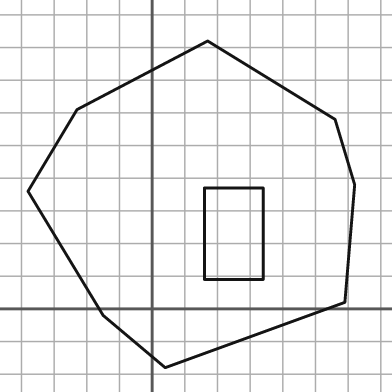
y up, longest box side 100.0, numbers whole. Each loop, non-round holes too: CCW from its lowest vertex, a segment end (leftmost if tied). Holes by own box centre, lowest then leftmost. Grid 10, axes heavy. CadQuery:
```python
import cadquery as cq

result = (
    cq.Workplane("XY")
    .moveTo(4.0, -18.0)
    .lineTo(59.0, 2.0)
    .lineTo(62.0, 38.0)
    .lineTo(56.0, 58.0)
    .lineTo(17.0, 82.0)
    .lineTo(-23.0, 61.0)
    .lineTo(-38.0, 36.0)
    .lineTo(-15.0, -2.0)
    .close()
    .moveTo(16.0, 9.0)
    .lineTo(34.0, 9.0)
    .lineTo(34.0, 37.0)
    .lineTo(16.0, 37.0)
    .close()
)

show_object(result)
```